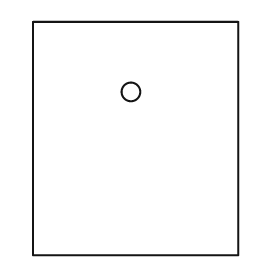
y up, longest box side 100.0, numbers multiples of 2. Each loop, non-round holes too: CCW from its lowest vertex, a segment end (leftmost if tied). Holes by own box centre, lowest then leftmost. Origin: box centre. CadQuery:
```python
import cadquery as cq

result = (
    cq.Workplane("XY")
    .moveTo(-44.0, -50.0)
    .lineTo(44.0, -50.0)
    .lineTo(44.0, 50.0)
    .lineTo(-44.0, 50.0)
    .close()
    .moveTo(-2.0, 20.0)
    .circle(4.0)
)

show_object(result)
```